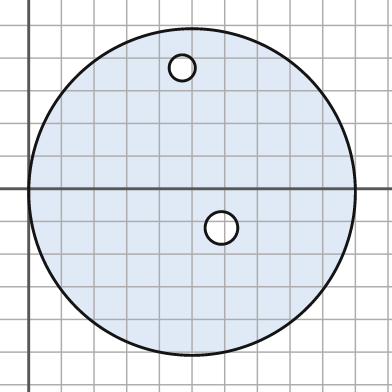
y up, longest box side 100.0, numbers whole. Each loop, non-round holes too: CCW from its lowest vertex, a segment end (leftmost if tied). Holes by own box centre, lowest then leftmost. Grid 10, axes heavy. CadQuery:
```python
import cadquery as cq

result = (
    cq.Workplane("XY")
    .moveTo(50.0, -1.0)
    .circle(50.0)
    .moveTo(59.0, -12.0)
    .circle(5.0)
    .moveTo(47.0, 37.0)
    .circle(4.0)
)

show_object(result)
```